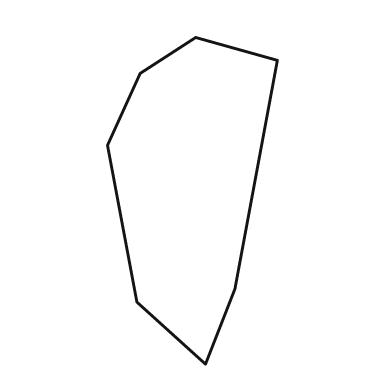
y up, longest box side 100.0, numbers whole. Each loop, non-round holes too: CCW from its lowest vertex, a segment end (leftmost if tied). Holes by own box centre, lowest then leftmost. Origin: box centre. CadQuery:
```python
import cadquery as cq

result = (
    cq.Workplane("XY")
    .moveTo(4.0, -50.0)
    .lineTo(13.0, -27.0)
    .lineTo(26.0, 43.0)
    .lineTo(1.0, 50.0)
    .lineTo(-16.0, 39.0)
    .lineTo(-26.0, 17.0)
    .lineTo(-17.0, -31.0)
    .close()
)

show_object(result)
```